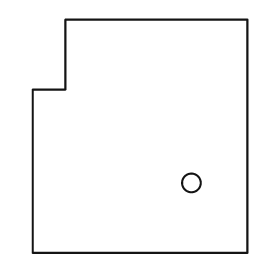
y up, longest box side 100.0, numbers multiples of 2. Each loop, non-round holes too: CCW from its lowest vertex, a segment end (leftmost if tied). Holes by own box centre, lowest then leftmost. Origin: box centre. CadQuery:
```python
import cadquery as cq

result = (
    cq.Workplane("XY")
    .moveTo(-46.0, -50.0)
    .lineTo(46.0, -50.0)
    .lineTo(46.0, 50.0)
    .lineTo(-32.0, 50.0)
    .lineTo(-32.0, 20.0)
    .lineTo(-46.0, 20.0)
    .close()
    .moveTo(22.0, -20.0)
    .circle(4.0)
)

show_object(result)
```